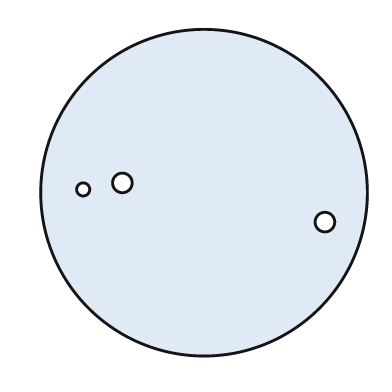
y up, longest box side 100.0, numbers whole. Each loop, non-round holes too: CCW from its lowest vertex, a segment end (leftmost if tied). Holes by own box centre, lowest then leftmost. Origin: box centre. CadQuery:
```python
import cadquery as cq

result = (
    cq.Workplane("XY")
    .moveTo(0.0, 0.0)
    .circle(50.0)
    .moveTo(37.0, -9.0)
    .circle(3.0)
    .moveTo(-37.0, 1.0)
    .circle(2.0)
    .moveTo(-25.0, 3.0)
    .circle(3.0)
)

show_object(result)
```